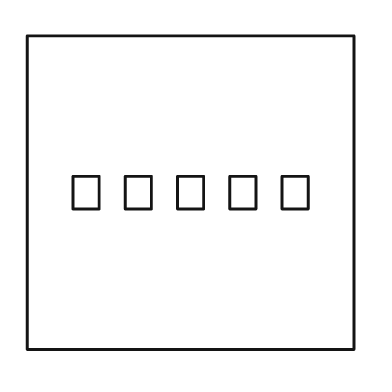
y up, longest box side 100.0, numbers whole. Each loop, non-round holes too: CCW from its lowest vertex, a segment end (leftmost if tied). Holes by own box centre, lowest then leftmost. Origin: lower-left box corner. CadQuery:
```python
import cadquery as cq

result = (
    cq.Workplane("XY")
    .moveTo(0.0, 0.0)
    .lineTo(100.0, 0.0)
    .lineTo(100.0, 96.0)
    .lineTo(0.0, 96.0)
    .close()
    .moveTo(14.0, 43.0)
    .lineTo(22.0, 43.0)
    .lineTo(22.0, 53.0)
    .lineTo(14.0, 53.0)
    .close()
    .moveTo(30.0, 43.0)
    .lineTo(38.0, 43.0)
    .lineTo(38.0, 53.0)
    .lineTo(30.0, 53.0)
    .close()
    .moveTo(46.0, 43.0)
    .lineTo(54.0, 43.0)
    .lineTo(54.0, 53.0)
    .lineTo(46.0, 53.0)
    .close()
    .moveTo(62.0, 43.0)
    .lineTo(70.0, 43.0)
    .lineTo(70.0, 53.0)
    .lineTo(62.0, 53.0)
    .close()
    .moveTo(78.0, 43.0)
    .lineTo(86.0, 43.0)
    .lineTo(86.0, 53.0)
    .lineTo(78.0, 53.0)
    .close()
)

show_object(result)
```